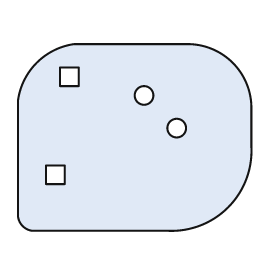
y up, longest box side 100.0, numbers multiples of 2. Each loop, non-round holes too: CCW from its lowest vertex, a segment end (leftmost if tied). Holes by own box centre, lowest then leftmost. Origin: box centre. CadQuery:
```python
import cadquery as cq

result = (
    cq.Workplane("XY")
    .moveTo(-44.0, -40.0)
    .lineTo(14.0, -40.0)
    .threePointArc((40.0, -30.0), (50.0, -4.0))
    .lineTo(50.0, 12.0)
    .threePointArc((42.0, 32.0), (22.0, 40.0))
    .lineTo(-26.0, 40.0)
    .threePointArc((-42.0, 32.0), (-50.0, 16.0))
    .lineTo(-50.0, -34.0)
    .threePointArc((-48.0, -38.0), (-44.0, -40.0))
    .close()
    .moveTo(-38.0, -20.0)
    .lineTo(-30.0, -20.0)
    .lineTo(-30.0, -12.0)
    .lineTo(-38.0, -12.0)
    .close()
    .moveTo(18.0, 4.0)
    .circle(4.0)
    .moveTo(4.0, 18.0)
    .circle(4.0)
    .moveTo(-32.0, 22.0)
    .lineTo(-24.0, 22.0)
    .lineTo(-24.0, 30.0)
    .lineTo(-32.0, 30.0)
    .close()
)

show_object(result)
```